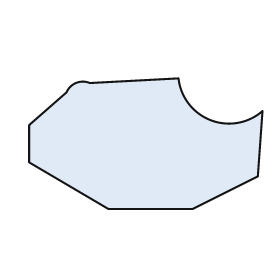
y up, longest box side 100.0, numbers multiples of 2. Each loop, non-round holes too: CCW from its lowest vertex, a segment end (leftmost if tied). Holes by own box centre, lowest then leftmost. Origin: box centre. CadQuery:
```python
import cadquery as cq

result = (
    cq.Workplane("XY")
    .moveTo(-16.0, -28.0)
    .lineTo(20.0, -28.0)
    .lineTo(48.0, -14.0)
    .lineTo(50.0, 14.0)
    .threePointArc((28.0, 10.0), (14.0, 28.0))
    .lineTo(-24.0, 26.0)
    .threePointArc((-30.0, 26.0), (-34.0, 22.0))
    .lineTo(-50.0, 8.0)
    .lineTo(-50.0, -8.0)
    .close()
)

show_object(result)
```